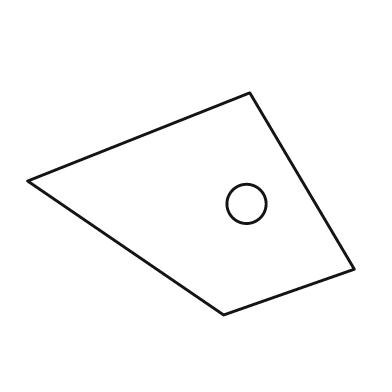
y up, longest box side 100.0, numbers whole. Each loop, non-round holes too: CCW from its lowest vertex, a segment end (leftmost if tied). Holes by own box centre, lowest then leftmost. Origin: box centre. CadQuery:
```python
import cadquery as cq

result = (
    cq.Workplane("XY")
    .moveTo(10.0, -34.0)
    .lineTo(50.0, -20.0)
    .lineTo(18.0, 34.0)
    .lineTo(-50.0, 7.0)
    .close()
    .moveTo(17.0, 0.0)
    .circle(6.0)
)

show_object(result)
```